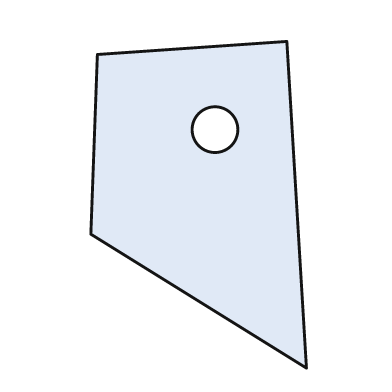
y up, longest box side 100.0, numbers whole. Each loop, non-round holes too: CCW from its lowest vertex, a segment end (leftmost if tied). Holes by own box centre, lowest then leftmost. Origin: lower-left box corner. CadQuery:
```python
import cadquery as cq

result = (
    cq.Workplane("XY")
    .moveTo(66.0, 0.0)
    .lineTo(60.0, 100.0)
    .lineTo(2.0, 96.0)
    .lineTo(0.0, 41.0)
    .close()
    .moveTo(38.0, 73.0)
    .circle(7.0)
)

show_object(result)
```